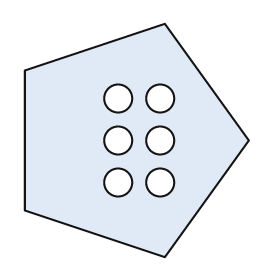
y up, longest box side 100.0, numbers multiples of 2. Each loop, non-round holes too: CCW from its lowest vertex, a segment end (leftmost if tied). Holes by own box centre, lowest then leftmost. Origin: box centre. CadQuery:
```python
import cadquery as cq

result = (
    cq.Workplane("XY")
    .moveTo(12.0, -50.0)
    .lineTo(48.0, 0.0)
    .lineTo(12.0, 50.0)
    .lineTo(-48.0, 30.0)
    .lineTo(-48.0, -30.0)
    .close()
    .moveTo(-8.0, -18.0)
    .circle(6.0)
    .moveTo(10.0, -18.0)
    .circle(6.0)
    .moveTo(-8.0, 0.0)
    .circle(6.0)
    .moveTo(10.0, 0.0)
    .circle(6.0)
    .moveTo(-8.0, 18.0)
    .circle(6.0)
    .moveTo(10.0, 18.0)
    .circle(6.0)
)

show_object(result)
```